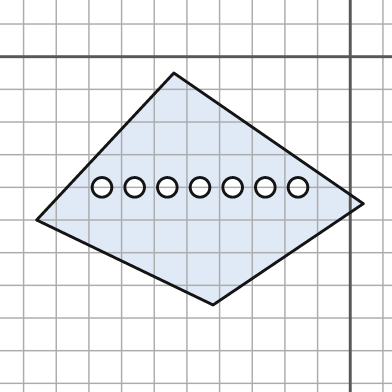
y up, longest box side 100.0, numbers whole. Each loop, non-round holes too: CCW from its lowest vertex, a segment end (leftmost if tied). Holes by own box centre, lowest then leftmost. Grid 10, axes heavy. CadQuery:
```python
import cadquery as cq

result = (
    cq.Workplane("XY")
    .moveTo(-42.0, -76.0)
    .lineTo(4.0, -45.0)
    .lineTo(-54.0, -5.0)
    .lineTo(-96.0, -50.0)
    .close()
    .moveTo(-76.0, -40.0)
    .circle(3.0)
    .moveTo(-66.0, -40.0)
    .circle(3.0)
    .moveTo(-56.0, -40.0)
    .circle(3.0)
    .moveTo(-46.0, -40.0)
    .circle(3.0)
    .moveTo(-36.0, -40.0)
    .circle(3.0)
    .moveTo(-26.0, -40.0)
    .circle(3.0)
    .moveTo(-16.0, -40.0)
    .circle(3.0)
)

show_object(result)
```